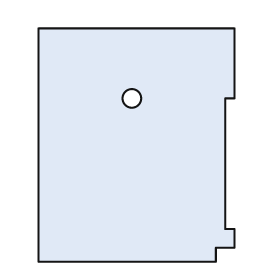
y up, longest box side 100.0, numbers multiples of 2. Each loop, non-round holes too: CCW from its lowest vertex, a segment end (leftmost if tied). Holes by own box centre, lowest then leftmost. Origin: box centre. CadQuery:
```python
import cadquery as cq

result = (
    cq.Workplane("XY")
    .moveTo(-42.0, -50.0)
    .lineTo(34.0, -50.0)
    .lineTo(34.0, -44.0)
    .lineTo(42.0, -44.0)
    .lineTo(42.0, -36.0)
    .lineTo(38.0, -36.0)
    .lineTo(38.0, 20.0)
    .lineTo(42.0, 20.0)
    .lineTo(42.0, 50.0)
    .lineTo(-42.0, 50.0)
    .close()
    .moveTo(-2.0, 20.0)
    .circle(4.0)
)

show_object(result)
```